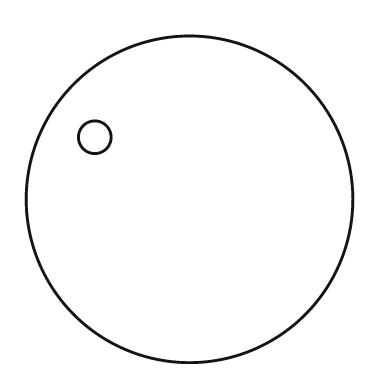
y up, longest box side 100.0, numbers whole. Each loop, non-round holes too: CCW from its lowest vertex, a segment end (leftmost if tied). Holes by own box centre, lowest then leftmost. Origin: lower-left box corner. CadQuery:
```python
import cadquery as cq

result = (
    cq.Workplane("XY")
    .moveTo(50.0, 50.0)
    .circle(50.0)
    .moveTo(21.0, 69.0)
    .circle(5.0)
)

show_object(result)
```